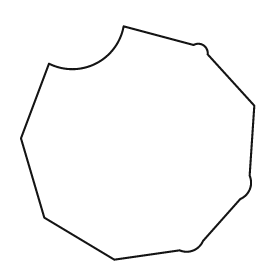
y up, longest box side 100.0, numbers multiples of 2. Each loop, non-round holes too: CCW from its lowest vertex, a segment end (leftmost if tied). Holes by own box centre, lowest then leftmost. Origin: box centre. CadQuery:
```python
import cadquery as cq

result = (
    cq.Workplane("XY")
    .moveTo(-10.0, -50.0)
    .lineTo(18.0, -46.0)
    .threePointArc((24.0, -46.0), (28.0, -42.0))
    .lineTo(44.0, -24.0)
    .threePointArc((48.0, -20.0), (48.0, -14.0))
    .lineTo(50.0, 16.0)
    .lineTo(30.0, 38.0)
    .threePointArc((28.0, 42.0), (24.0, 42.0))
    .lineTo(-6.0, 50.0)
    .threePointArc((-18.0, 34.0), (-38.0, 34.0))
    .lineTo(-50.0, 2.0)
    .lineTo(-40.0, -32.0)
    .close()
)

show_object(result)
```